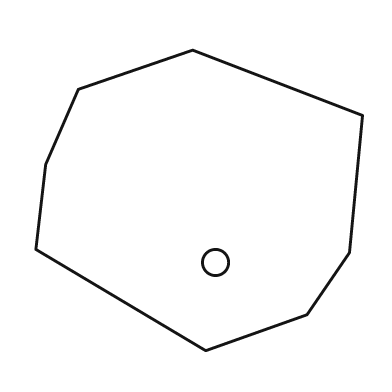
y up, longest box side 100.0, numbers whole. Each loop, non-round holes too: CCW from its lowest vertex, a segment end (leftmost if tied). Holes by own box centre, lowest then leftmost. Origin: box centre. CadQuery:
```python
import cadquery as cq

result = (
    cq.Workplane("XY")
    .moveTo(2.0, -46.0)
    .lineTo(33.0, -35.0)
    .lineTo(46.0, -16.0)
    .lineTo(50.0, 26.0)
    .lineTo(-2.0, 46.0)
    .lineTo(-37.0, 34.0)
    .lineTo(-47.0, 11.0)
    .lineTo(-50.0, -15.0)
    .close()
    .moveTo(5.0, -19.0)
    .circle(4.0)
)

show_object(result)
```